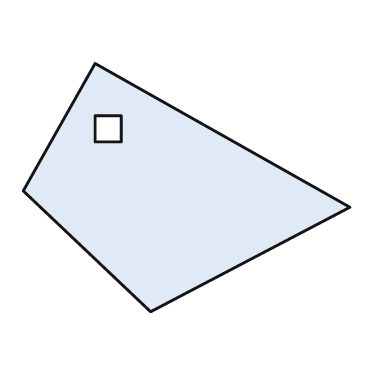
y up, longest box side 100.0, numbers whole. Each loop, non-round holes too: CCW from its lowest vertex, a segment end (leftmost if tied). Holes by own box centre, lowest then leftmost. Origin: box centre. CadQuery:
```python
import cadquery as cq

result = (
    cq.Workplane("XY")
    .moveTo(-11.0, -38.0)
    .lineTo(50.0, -6.0)
    .lineTo(-28.0, 38.0)
    .lineTo(-50.0, -1.0)
    .close()
    .moveTo(-28.0, 14.0)
    .lineTo(-20.0, 14.0)
    .lineTo(-20.0, 22.0)
    .lineTo(-28.0, 22.0)
    .close()
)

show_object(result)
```